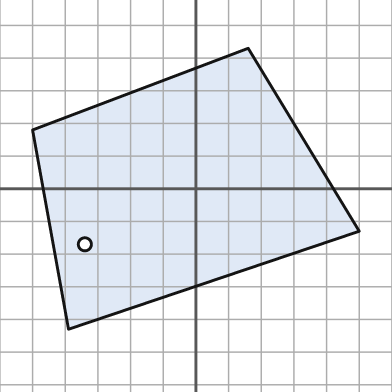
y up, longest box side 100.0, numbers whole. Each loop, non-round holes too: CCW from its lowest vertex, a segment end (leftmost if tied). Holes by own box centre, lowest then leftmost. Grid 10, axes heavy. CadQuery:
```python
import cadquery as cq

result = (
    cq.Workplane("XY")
    .moveTo(-39.0, -43.0)
    .lineTo(50.0, -13.0)
    .lineTo(16.0, 43.0)
    .lineTo(-50.0, 18.0)
    .close()
    .moveTo(-34.0, -17.0)
    .circle(2.0)
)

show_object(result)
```